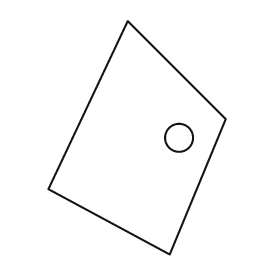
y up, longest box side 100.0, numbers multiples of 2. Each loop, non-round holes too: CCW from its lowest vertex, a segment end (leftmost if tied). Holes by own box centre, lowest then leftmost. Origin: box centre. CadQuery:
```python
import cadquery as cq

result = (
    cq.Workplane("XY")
    .moveTo(14.0, -50.0)
    .lineTo(38.0, 8.0)
    .lineTo(-4.0, 50.0)
    .lineTo(-38.0, -22.0)
    .close()
    .moveTo(18.0, 0.0)
    .circle(6.0)
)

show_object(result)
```